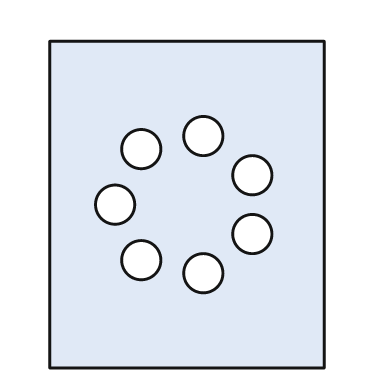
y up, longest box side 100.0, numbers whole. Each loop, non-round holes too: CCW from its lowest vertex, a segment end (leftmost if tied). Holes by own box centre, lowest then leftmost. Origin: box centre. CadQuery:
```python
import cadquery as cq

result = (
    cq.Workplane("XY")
    .moveTo(-42.0, -50.0)
    .lineTo(42.0, -50.0)
    .lineTo(42.0, 50.0)
    .lineTo(-42.0, 50.0)
    .close()
    .moveTo(5.0, -21.0)
    .circle(6.0)
    .moveTo(-14.0, -17.0)
    .circle(6.0)
    .moveTo(20.0, -9.0)
    .circle(6.0)
    .moveTo(-22.0, 0.0)
    .circle(6.0)
    .moveTo(20.0, 9.0)
    .circle(6.0)
    .moveTo(-14.0, 17.0)
    .circle(6.0)
    .moveTo(5.0, 21.0)
    .circle(6.0)
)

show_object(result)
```